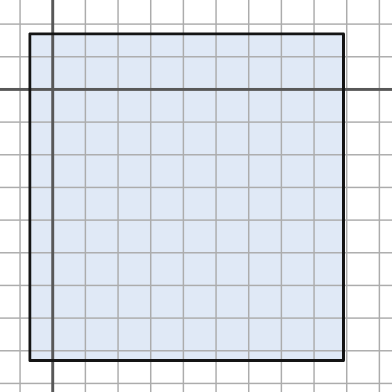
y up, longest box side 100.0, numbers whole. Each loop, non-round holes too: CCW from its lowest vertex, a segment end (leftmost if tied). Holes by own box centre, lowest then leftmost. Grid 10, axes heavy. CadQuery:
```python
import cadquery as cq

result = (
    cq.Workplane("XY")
    .moveTo(-7.0, -83.0)
    .lineTo(89.0, -83.0)
    .lineTo(89.0, 17.0)
    .lineTo(-7.0, 17.0)
    .close()
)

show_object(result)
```